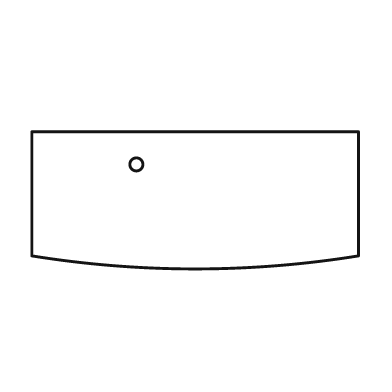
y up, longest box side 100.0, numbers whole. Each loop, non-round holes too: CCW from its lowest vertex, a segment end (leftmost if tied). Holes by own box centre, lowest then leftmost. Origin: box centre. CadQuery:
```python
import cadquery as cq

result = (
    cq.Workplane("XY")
    .moveTo(-50.0, -17.0)
    .threePointArc((0.0, -21.0), (50.0, -17.0))
    .lineTo(50.0, 21.0)
    .lineTo(-50.0, 21.0)
    .close()
    .moveTo(-18.0, 11.0)
    .circle(2.0)
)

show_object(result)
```